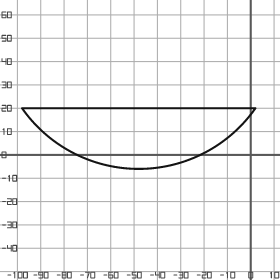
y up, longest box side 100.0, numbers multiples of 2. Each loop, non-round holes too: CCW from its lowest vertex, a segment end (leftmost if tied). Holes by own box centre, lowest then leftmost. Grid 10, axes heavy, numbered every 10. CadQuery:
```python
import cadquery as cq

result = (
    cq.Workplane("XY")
    .moveTo(-98.0, 20.0)
    .threePointArc((-48.0, -6.0), (2.0, 20.0))
    .close()
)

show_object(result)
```